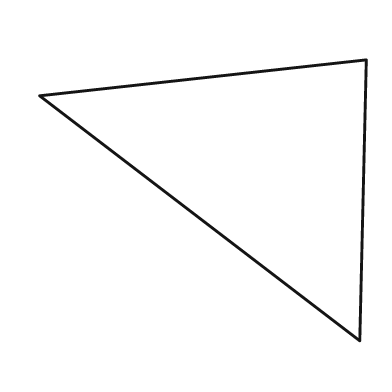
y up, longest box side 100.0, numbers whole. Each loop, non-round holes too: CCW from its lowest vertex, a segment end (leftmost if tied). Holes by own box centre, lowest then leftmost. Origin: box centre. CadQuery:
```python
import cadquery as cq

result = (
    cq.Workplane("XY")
    .moveTo(48.0, -43.0)
    .lineTo(50.0, 43.0)
    .lineTo(-50.0, 32.0)
    .close()
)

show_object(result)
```